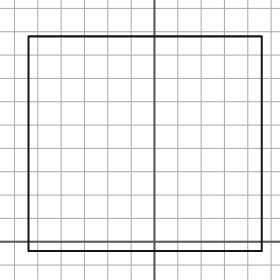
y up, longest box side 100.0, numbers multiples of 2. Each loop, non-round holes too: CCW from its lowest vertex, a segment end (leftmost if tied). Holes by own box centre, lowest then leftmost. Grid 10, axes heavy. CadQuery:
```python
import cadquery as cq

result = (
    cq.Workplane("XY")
    .moveTo(-54.0, -4.0)
    .lineTo(46.0, -4.0)
    .lineTo(46.0, 88.0)
    .lineTo(-54.0, 88.0)
    .close()
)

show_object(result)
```